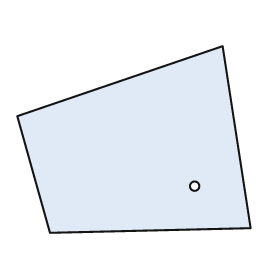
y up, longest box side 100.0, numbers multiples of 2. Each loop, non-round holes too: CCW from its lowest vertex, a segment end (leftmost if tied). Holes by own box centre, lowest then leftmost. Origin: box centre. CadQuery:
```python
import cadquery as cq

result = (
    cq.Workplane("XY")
    .moveTo(-36.0, -40.0)
    .lineTo(50.0, -38.0)
    .lineTo(38.0, 40.0)
    .lineTo(-50.0, 10.0)
    .close()
    .moveTo(26.0, -20.0)
    .circle(2.0)
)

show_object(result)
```